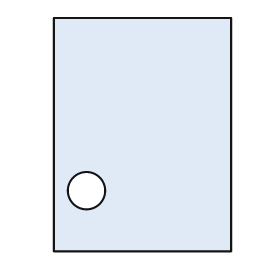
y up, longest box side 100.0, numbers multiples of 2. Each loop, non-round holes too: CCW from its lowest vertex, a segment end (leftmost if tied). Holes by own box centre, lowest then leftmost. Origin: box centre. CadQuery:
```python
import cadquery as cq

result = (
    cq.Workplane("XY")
    .moveTo(-38.0, -50.0)
    .lineTo(38.0, -50.0)
    .lineTo(38.0, 50.0)
    .lineTo(-38.0, 50.0)
    .close()
    .moveTo(-24.0, -24.0)
    .circle(8.0)
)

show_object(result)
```